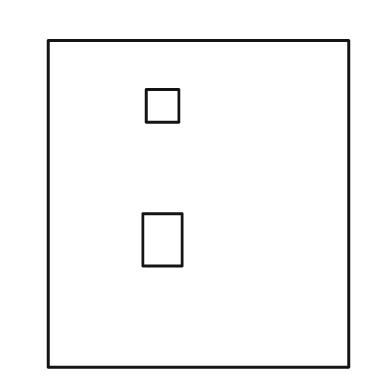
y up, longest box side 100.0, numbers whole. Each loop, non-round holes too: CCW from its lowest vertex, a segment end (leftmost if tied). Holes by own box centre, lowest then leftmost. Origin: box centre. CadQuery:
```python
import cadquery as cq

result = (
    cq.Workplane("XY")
    .moveTo(-46.0, -50.0)
    .lineTo(46.0, -50.0)
    .lineTo(46.0, 50.0)
    .lineTo(-46.0, 50.0)
    .close()
    .moveTo(-17.0, -19.0)
    .lineTo(-5.0, -19.0)
    .lineTo(-5.0, -3.0)
    .lineTo(-17.0, -3.0)
    .close()
    .moveTo(-16.0, 25.0)
    .lineTo(-6.0, 25.0)
    .lineTo(-6.0, 35.0)
    .lineTo(-16.0, 35.0)
    .close()
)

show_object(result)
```